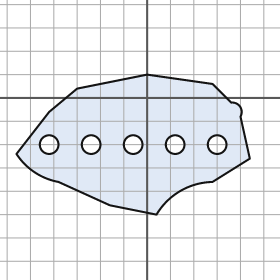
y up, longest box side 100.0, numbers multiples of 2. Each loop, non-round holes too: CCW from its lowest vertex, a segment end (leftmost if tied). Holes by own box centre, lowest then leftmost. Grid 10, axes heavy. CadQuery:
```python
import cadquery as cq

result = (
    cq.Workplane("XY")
    .moveTo(4.0, -50.0)
    .threePointArc((14.0, -40.0), (28.0, -36.0))
    .lineTo(44.0, -26.0)
    .lineTo(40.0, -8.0)
    .threePointArc((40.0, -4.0), (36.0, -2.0))
    .lineTo(28.0, 6.0)
    .lineTo(0.0, 10.0)
    .lineTo(-30.0, 4.0)
    .lineTo(-42.0, -6.0)
    .lineTo(-56.0, -24.0)
    .threePointArc((-48.0, -32.0), (-38.0, -36.0))
    .lineTo(-16.0, -46.0)
    .close()
    .moveTo(-42.0, -20.0)
    .circle(4.0)
    .moveTo(-24.0, -20.0)
    .circle(4.0)
    .moveTo(-6.0, -20.0)
    .circle(4.0)
    .moveTo(12.0, -20.0)
    .circle(4.0)
    .moveTo(30.0, -20.0)
    .circle(4.0)
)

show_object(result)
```